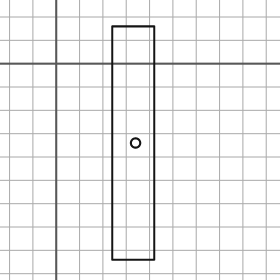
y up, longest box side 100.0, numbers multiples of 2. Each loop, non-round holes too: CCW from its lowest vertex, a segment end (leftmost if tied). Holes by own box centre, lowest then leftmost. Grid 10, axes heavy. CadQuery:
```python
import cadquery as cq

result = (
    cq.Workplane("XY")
    .moveTo(24.0, -84.0)
    .lineTo(42.0, -84.0)
    .lineTo(42.0, 16.0)
    .lineTo(24.0, 16.0)
    .close()
    .moveTo(34.0, -34.0)
    .circle(2.0)
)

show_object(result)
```